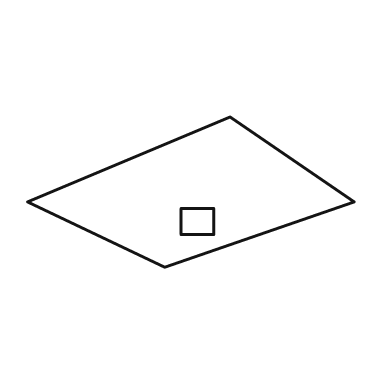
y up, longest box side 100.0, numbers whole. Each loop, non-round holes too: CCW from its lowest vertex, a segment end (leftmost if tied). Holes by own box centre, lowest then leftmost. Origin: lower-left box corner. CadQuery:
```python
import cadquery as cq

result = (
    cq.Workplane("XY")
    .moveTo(42.0, 0.0)
    .lineTo(100.0, 20.0)
    .lineTo(62.0, 46.0)
    .lineTo(0.0, 20.0)
    .close()
    .moveTo(47.0, 10.0)
    .lineTo(57.0, 10.0)
    .lineTo(57.0, 18.0)
    .lineTo(47.0, 18.0)
    .close()
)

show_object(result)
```